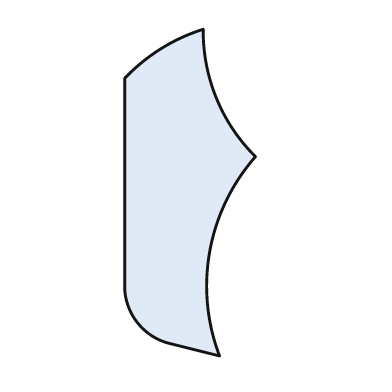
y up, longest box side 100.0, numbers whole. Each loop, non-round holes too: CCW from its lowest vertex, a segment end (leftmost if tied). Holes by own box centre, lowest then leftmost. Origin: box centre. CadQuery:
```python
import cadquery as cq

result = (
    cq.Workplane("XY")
    .moveTo(9.0, -50.0)
    .threePointArc((6.0, -18.0), (20.0, 11.0))
    .threePointArc((8.0, 29.0), (4.0, 50.0))
    .threePointArc((-9.0, 44.0), (-20.0, 35.0))
    .lineTo(-20.0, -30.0)
    .threePointArc((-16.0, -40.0), (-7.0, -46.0))
    .close()
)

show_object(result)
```